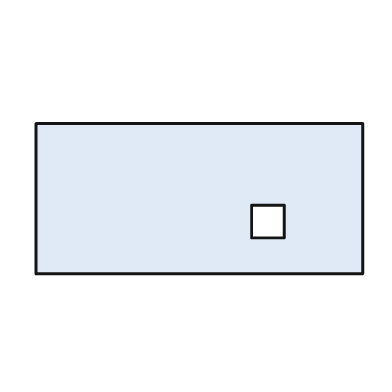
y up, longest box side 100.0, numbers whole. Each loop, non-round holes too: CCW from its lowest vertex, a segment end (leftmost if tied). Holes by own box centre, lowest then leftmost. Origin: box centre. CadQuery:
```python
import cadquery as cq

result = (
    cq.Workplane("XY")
    .moveTo(-50.0, -23.0)
    .lineTo(50.0, -23.0)
    .lineTo(50.0, 23.0)
    .lineTo(-50.0, 23.0)
    .close()
    .moveTo(16.0, -12.0)
    .lineTo(26.0, -12.0)
    .lineTo(26.0, -2.0)
    .lineTo(16.0, -2.0)
    .close()
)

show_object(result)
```